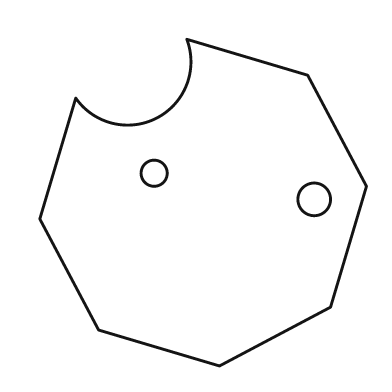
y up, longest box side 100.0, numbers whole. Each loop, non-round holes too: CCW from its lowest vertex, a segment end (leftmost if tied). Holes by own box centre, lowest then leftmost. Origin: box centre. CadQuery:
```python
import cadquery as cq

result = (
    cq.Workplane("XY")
    .moveTo(5.0, -50.0)
    .lineTo(39.0, -32.0)
    .lineTo(50.0, 5.0)
    .lineTo(32.0, 39.0)
    .lineTo(-5.0, 50.0)
    .threePointArc((-14.0, 26.0), (-39.0, 32.0))
    .lineTo(-50.0, -5.0)
    .lineTo(-32.0, -39.0)
    .close()
    .moveTo(34.0, 1.0)
    .circle(5.0)
    .moveTo(-15.0, 9.0)
    .circle(4.0)
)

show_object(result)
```